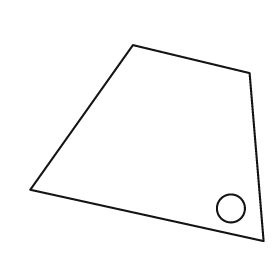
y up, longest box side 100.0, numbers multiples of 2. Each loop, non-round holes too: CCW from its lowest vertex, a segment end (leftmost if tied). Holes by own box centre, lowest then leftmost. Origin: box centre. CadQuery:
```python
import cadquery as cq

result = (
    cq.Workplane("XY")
    .moveTo(50.0, -42.0)
    .lineTo(44.0, 30.0)
    .lineTo(-6.0, 42.0)
    .lineTo(-50.0, -20.0)
    .close()
    .moveTo(36.0, -28.0)
    .circle(6.0)
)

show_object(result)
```